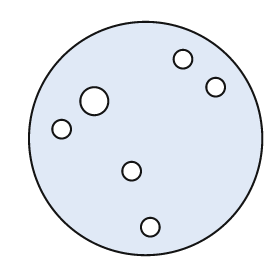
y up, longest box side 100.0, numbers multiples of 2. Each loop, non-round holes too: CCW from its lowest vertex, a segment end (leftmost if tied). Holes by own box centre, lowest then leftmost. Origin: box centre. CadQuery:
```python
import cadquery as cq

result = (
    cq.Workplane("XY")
    .moveTo(0.0, 0.0)
    .circle(50.0)
    .moveTo(2.0, -38.0)
    .circle(4.0)
    .moveTo(-6.0, -14.0)
    .circle(4.0)
    .moveTo(-36.0, 4.0)
    .circle(4.0)
    .moveTo(-22.0, 16.0)
    .circle(6.0)
    .moveTo(30.0, 22.0)
    .circle(4.0)
    .moveTo(16.0, 34.0)
    .circle(4.0)
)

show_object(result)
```